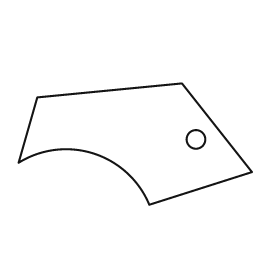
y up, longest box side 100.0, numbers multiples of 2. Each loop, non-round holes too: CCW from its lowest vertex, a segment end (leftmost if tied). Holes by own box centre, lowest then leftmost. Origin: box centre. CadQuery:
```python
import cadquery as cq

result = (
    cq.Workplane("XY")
    .moveTo(6.0, -26.0)
    .lineTo(50.0, -12.0)
    .lineTo(20.0, 26.0)
    .lineTo(-42.0, 20.0)
    .lineTo(-50.0, -8.0)
    .threePointArc((-18.0, -4.0), (6.0, -26.0))
    .close()
    .moveTo(26.0, 2.0)
    .circle(4.0)
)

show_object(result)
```